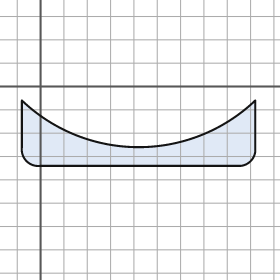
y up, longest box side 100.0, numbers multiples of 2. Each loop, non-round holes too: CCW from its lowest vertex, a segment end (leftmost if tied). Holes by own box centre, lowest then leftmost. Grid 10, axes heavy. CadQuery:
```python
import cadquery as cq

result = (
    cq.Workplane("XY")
    .moveTo(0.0, -34.0)
    .lineTo(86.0, -34.0)
    .threePointArc((90.0, -32.0), (92.0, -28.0))
    .lineTo(92.0, -6.0)
    .threePointArc((42.0, -26.0), (-8.0, -6.0))
    .lineTo(-8.0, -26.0)
    .threePointArc((-6.0, -32.0), (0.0, -34.0))
    .close()
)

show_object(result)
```